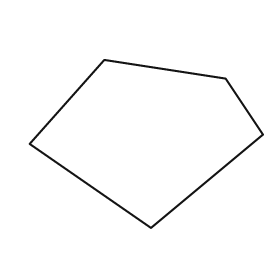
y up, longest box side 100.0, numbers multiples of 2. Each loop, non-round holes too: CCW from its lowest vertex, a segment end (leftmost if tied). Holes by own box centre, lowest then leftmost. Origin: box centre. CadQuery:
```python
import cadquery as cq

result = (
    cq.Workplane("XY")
    .moveTo(2.0, -36.0)
    .lineTo(50.0, 4.0)
    .lineTo(34.0, 28.0)
    .lineTo(-18.0, 36.0)
    .lineTo(-50.0, 0.0)
    .close()
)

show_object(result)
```